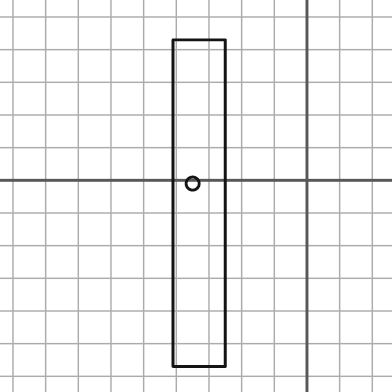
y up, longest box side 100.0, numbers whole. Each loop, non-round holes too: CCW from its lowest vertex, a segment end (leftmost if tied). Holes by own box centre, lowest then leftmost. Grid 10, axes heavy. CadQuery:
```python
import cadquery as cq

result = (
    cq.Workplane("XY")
    .moveTo(-41.0, -57.0)
    .lineTo(-25.0, -57.0)
    .lineTo(-25.0, 43.0)
    .lineTo(-41.0, 43.0)
    .close()
    .moveTo(-35.0, -1.0)
    .circle(2.0)
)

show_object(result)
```